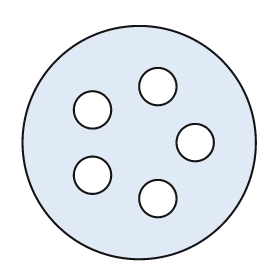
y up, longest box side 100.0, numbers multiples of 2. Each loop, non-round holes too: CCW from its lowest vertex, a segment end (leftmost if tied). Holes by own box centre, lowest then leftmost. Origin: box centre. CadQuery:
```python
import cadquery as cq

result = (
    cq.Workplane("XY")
    .moveTo(0.0, 0.0)
    .circle(50.0)
    .moveTo(8.0, -24.0)
    .circle(8.0)
    .moveTo(-20.0, -14.0)
    .circle(8.0)
    .moveTo(24.0, 0.0)
    .circle(8.0)
    .moveTo(-20.0, 14.0)
    .circle(8.0)
    .moveTo(8.0, 24.0)
    .circle(8.0)
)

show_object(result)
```